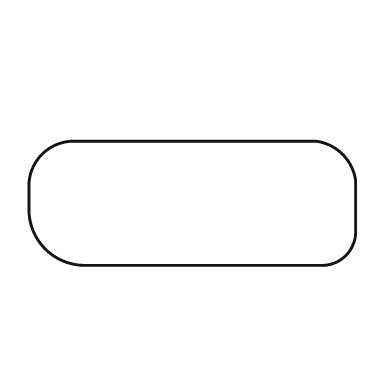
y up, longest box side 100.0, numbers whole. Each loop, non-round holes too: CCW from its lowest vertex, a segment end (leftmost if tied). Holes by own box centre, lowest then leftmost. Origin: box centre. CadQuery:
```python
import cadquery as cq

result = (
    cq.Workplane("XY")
    .moveTo(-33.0, -19.0)
    .lineTo(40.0, -19.0)
    .threePointArc((47.0, -16.0), (50.0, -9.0))
    .lineTo(50.0, 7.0)
    .threePointArc((46.0, 15.0), (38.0, 19.0))
    .lineTo(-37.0, 19.0)
    .threePointArc((-46.0, 15.0), (-50.0, 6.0))
    .lineTo(-50.0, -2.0)
    .threePointArc((-45.0, -14.0), (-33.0, -19.0))
    .close()
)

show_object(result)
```